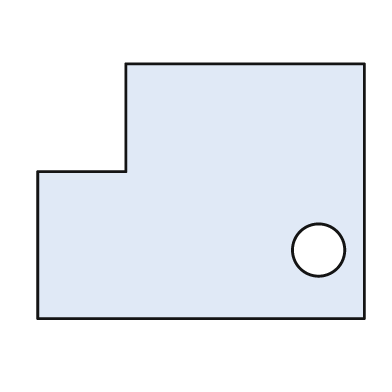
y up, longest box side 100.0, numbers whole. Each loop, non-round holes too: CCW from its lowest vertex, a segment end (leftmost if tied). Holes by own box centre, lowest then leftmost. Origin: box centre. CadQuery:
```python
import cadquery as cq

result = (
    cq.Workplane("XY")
    .moveTo(-50.0, -39.0)
    .lineTo(50.0, -39.0)
    .lineTo(50.0, 39.0)
    .lineTo(-23.0, 39.0)
    .lineTo(-23.0, 6.0)
    .lineTo(-50.0, 6.0)
    .close()
    .moveTo(36.0, -18.0)
    .circle(8.0)
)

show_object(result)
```